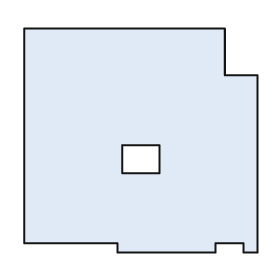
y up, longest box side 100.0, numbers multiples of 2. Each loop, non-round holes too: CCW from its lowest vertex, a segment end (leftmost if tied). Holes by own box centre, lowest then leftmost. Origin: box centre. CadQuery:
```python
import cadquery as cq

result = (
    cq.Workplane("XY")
    .moveTo(-10.0, -48.0)
    .lineTo(32.0, -48.0)
    .lineTo(32.0, -44.0)
    .lineTo(44.0, -44.0)
    .lineTo(44.0, -48.0)
    .lineTo(50.0, -48.0)
    .lineTo(50.0, 28.0)
    .lineTo(36.0, 28.0)
    .lineTo(36.0, 48.0)
    .lineTo(-50.0, 48.0)
    .lineTo(-50.0, -44.0)
    .lineTo(-10.0, -44.0)
    .close()
    .moveTo(-8.0, -14.0)
    .lineTo(8.0, -14.0)
    .lineTo(8.0, -2.0)
    .lineTo(-8.0, -2.0)
    .close()
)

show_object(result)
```